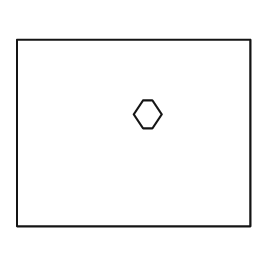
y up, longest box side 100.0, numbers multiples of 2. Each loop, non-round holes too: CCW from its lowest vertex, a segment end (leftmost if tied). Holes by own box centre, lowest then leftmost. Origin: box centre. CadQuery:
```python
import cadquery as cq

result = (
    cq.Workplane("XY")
    .moveTo(-50.0, -40.0)
    .lineTo(50.0, -40.0)
    .lineTo(50.0, 40.0)
    .lineTo(-50.0, 40.0)
    .close()
    .moveTo(4.0, 2.0)
    .lineTo(8.0, 2.0)
    .lineTo(12.0, 8.0)
    .lineTo(8.0, 14.0)
    .lineTo(4.0, 14.0)
    .lineTo(0.0, 8.0)
    .close()
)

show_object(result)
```